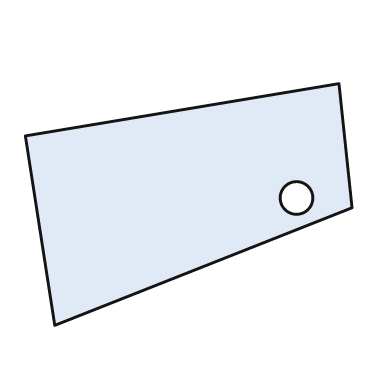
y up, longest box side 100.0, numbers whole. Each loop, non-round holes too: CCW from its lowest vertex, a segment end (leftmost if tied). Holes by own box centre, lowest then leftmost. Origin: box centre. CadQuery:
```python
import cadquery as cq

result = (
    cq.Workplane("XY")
    .moveTo(-41.0, -37.0)
    .lineTo(50.0, -1.0)
    .lineTo(46.0, 37.0)
    .lineTo(-50.0, 21.0)
    .close()
    .moveTo(33.0, 2.0)
    .circle(5.0)
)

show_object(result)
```